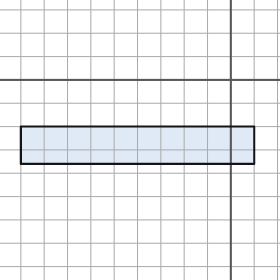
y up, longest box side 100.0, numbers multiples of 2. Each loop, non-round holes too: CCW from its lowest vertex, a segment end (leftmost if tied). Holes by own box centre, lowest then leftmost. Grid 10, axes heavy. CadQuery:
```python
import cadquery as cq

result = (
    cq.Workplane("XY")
    .moveTo(-90.0, -36.0)
    .lineTo(10.0, -36.0)
    .lineTo(10.0, -20.0)
    .lineTo(-90.0, -20.0)
    .close()
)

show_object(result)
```